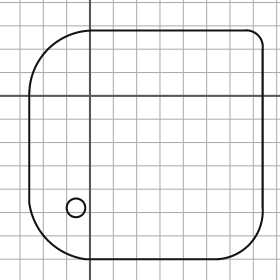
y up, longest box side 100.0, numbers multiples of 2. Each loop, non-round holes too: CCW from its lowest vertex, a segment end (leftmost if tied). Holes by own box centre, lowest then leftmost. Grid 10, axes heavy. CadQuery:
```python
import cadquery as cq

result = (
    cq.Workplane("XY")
    .moveTo(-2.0, -70.0)
    .lineTo(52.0, -70.0)
    .threePointArc((68.0, -64.0), (74.0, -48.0))
    .lineTo(74.0, 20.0)
    .threePointArc((72.0, 26.0), (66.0, 28.0))
    .lineTo(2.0, 28.0)
    .threePointArc((-18.0, 20.0), (-26.0, 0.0))
    .lineTo(-26.0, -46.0)
    .threePointArc((-18.0, -62.0), (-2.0, -70.0))
    .close()
    .moveTo(-6.0, -48.0)
    .circle(4.0)
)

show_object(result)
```